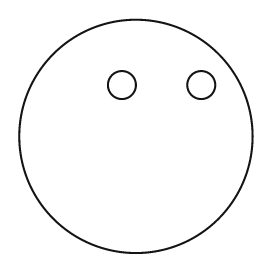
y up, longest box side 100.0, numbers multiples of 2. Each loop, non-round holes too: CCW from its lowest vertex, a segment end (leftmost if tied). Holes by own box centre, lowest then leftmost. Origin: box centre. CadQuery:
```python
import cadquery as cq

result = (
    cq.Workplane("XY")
    .moveTo(0.0, 0.0)
    .circle(50.0)
    .moveTo(-6.0, 22.0)
    .circle(6.0)
    .moveTo(28.0, 22.0)
    .circle(6.0)
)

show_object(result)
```